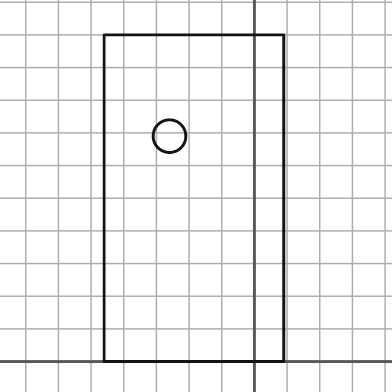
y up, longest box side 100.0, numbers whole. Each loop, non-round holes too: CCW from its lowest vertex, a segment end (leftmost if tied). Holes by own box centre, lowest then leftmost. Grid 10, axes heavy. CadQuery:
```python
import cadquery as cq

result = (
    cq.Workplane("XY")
    .moveTo(-46.0, 0.0)
    .lineTo(9.0, 0.0)
    .lineTo(9.0, 100.0)
    .lineTo(-46.0, 100.0)
    .close()
    .moveTo(-26.0, 69.0)
    .circle(5.0)
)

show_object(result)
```